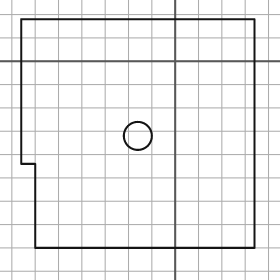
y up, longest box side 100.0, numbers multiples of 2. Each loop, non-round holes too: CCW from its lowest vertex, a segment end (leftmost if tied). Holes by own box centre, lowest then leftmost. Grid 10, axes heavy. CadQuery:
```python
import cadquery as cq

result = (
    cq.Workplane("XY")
    .moveTo(-60.0, -80.0)
    .lineTo(34.0, -80.0)
    .lineTo(34.0, 18.0)
    .lineTo(-66.0, 18.0)
    .lineTo(-66.0, -44.0)
    .lineTo(-60.0, -44.0)
    .close()
    .moveTo(-16.0, -32.0)
    .circle(6.0)
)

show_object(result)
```